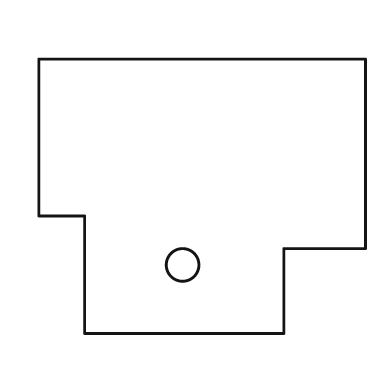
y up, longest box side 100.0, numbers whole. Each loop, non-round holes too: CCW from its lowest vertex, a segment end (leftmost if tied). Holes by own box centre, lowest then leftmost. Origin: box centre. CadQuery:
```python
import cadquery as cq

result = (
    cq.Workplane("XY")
    .moveTo(-36.0, -42.0)
    .lineTo(25.0, -42.0)
    .lineTo(25.0, -16.0)
    .lineTo(50.0, -16.0)
    .lineTo(50.0, 42.0)
    .lineTo(-50.0, 42.0)
    .lineTo(-50.0, -6.0)
    .lineTo(-36.0, -6.0)
    .close()
    .moveTo(-6.0, -21.0)
    .circle(5.0)
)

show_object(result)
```